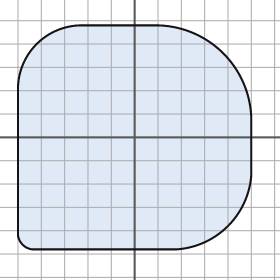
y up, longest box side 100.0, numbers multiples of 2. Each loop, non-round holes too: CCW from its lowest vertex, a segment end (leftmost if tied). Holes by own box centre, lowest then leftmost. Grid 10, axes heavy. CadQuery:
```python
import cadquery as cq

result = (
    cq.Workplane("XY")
    .moveTo(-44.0, -48.0)
    .lineTo(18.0, -48.0)
    .threePointArc((40.0, -38.0), (50.0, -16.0))
    .lineTo(50.0, 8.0)
    .threePointArc((38.0, 36.0), (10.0, 48.0))
    .lineTo(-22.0, 48.0)
    .threePointArc((-42.0, 40.0), (-50.0, 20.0))
    .lineTo(-50.0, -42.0)
    .threePointArc((-48.0, -46.0), (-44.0, -48.0))
    .close()
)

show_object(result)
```